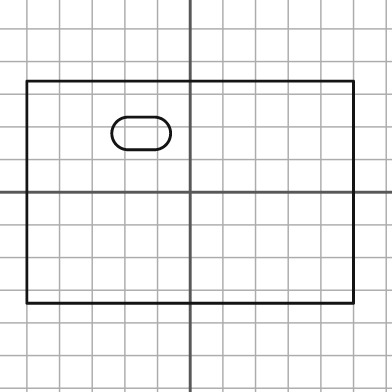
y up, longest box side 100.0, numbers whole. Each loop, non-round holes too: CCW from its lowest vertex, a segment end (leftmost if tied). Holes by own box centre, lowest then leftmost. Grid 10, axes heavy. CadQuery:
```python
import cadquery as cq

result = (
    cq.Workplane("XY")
    .moveTo(-50.0, -34.0)
    .lineTo(50.0, -34.0)
    .lineTo(50.0, 34.0)
    .lineTo(-50.0, 34.0)
    .close()
    .moveTo(-19.0, 13.0)
    .lineTo(-11.0, 13.0)
    .threePointArc((-6.0, 18.0), (-11.0, 23.0))
    .lineTo(-19.0, 23.0)
    .threePointArc((-24.0, 18.0), (-19.0, 13.0))
    .close()
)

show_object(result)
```